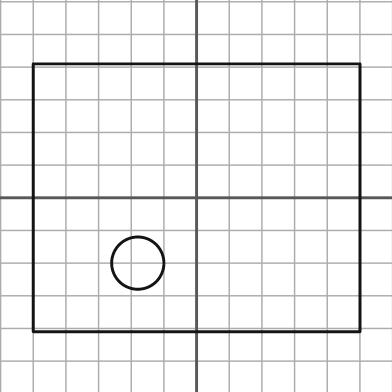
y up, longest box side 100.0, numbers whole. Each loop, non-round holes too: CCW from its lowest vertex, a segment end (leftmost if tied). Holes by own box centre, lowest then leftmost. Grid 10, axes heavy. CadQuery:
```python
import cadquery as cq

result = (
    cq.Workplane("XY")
    .moveTo(-50.0, -41.0)
    .lineTo(50.0, -41.0)
    .lineTo(50.0, 41.0)
    .lineTo(-50.0, 41.0)
    .close()
    .moveTo(-18.0, -20.0)
    .circle(8.0)
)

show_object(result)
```